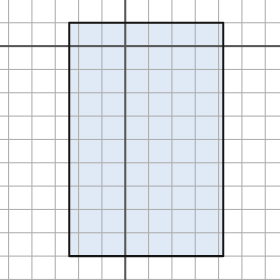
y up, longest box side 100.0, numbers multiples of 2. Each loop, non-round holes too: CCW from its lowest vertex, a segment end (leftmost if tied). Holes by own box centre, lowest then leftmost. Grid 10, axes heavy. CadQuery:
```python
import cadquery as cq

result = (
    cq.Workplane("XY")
    .moveTo(-24.0, -90.0)
    .lineTo(42.0, -90.0)
    .lineTo(42.0, 10.0)
    .lineTo(-24.0, 10.0)
    .close()
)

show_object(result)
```